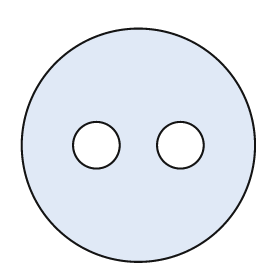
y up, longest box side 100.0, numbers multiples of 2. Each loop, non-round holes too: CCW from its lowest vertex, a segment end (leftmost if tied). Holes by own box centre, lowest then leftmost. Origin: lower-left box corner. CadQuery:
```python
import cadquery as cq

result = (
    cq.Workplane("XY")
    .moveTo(50.0, 50.0)
    .circle(50.0)
    .moveTo(32.0, 50.0)
    .circle(10.0)
    .moveTo(68.0, 50.0)
    .circle(10.0)
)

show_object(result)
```